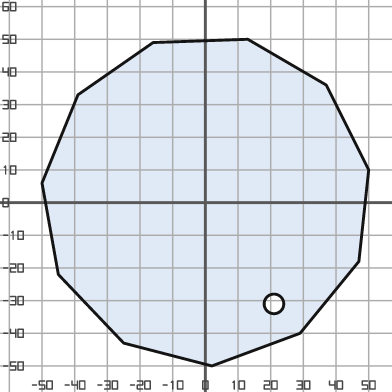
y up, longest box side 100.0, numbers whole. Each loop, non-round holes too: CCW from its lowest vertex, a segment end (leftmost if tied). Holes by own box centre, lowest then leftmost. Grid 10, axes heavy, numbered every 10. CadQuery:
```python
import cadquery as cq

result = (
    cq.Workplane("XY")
    .moveTo(2.0, -50.0)
    .lineTo(29.0, -40.0)
    .lineTo(47.0, -18.0)
    .lineTo(50.0, 10.0)
    .lineTo(37.0, 36.0)
    .lineTo(13.0, 50.0)
    .lineTo(-16.0, 49.0)
    .lineTo(-39.0, 33.0)
    .lineTo(-50.0, 6.0)
    .lineTo(-45.0, -22.0)
    .lineTo(-25.0, -43.0)
    .close()
    .moveTo(21.0, -31.0)
    .circle(3.0)
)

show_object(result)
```